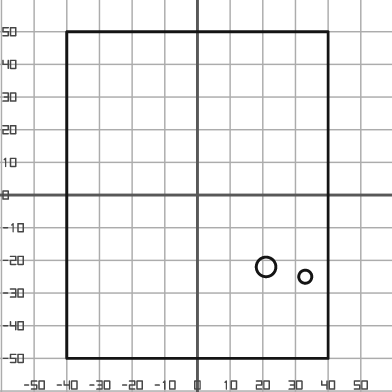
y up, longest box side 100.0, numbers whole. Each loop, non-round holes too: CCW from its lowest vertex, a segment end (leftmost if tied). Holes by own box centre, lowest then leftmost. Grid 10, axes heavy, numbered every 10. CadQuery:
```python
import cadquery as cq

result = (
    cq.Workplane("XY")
    .moveTo(-40.0, -50.0)
    .lineTo(40.0, -50.0)
    .lineTo(40.0, 50.0)
    .lineTo(-40.0, 50.0)
    .close()
    .moveTo(33.0, -25.0)
    .circle(2.0)
    .moveTo(21.0, -22.0)
    .circle(3.0)
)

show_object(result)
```